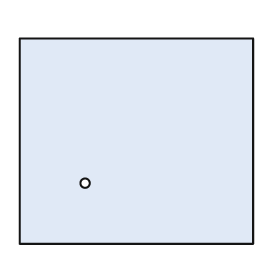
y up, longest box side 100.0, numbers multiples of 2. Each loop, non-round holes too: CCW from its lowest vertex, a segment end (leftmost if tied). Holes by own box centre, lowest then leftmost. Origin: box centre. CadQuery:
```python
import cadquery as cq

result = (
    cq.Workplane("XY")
    .moveTo(-50.0, -44.0)
    .lineTo(50.0, -44.0)
    .lineTo(50.0, 44.0)
    .lineTo(-50.0, 44.0)
    .close()
    .moveTo(-22.0, -18.0)
    .circle(2.0)
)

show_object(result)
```